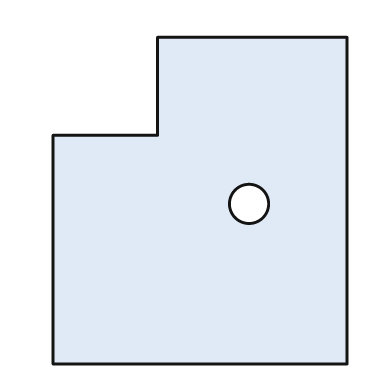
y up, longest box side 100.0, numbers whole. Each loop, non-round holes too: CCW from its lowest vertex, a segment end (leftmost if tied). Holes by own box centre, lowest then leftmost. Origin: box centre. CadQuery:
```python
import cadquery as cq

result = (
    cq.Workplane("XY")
    .moveTo(-45.0, -50.0)
    .lineTo(45.0, -50.0)
    .lineTo(45.0, 50.0)
    .lineTo(-13.0, 50.0)
    .lineTo(-13.0, 20.0)
    .lineTo(-45.0, 20.0)
    .close()
    .moveTo(15.0, -1.0)
    .circle(6.0)
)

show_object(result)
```